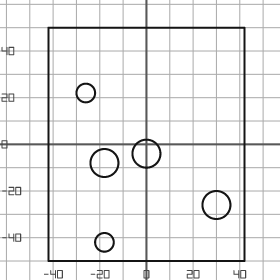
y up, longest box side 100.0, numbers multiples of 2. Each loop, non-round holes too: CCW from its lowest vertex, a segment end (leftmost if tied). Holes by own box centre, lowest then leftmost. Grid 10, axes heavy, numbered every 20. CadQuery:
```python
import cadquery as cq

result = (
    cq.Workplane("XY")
    .moveTo(-42.0, -50.0)
    .lineTo(42.0, -50.0)
    .lineTo(42.0, 50.0)
    .lineTo(-42.0, 50.0)
    .close()
    .moveTo(-18.0, -42.0)
    .circle(4.0)
    .moveTo(30.0, -26.0)
    .circle(6.0)
    .moveTo(-18.0, -8.0)
    .circle(6.0)
    .moveTo(0.0, -4.0)
    .circle(6.0)
    .moveTo(-26.0, 22.0)
    .circle(4.0)
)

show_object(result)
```